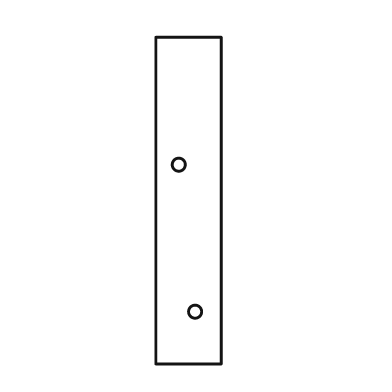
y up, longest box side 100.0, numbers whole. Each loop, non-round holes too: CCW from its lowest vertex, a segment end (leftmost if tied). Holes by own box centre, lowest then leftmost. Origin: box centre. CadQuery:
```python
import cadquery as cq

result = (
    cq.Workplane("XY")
    .moveTo(-10.0, -50.0)
    .lineTo(10.0, -50.0)
    .lineTo(10.0, 50.0)
    .lineTo(-10.0, 50.0)
    .close()
    .moveTo(2.0, -34.0)
    .circle(2.0)
    .moveTo(-3.0, 11.0)
    .circle(2.0)
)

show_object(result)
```